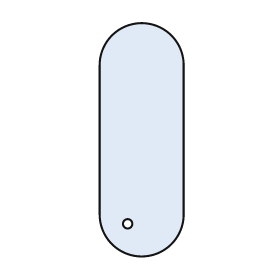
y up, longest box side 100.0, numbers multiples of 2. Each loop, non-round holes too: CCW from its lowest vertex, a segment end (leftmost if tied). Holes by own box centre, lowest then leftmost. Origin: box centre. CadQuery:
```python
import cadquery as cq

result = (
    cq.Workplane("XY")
    .moveTo(-18.0, -32.0)
    .threePointArc((0.0, -50.0), (18.0, -32.0))
    .lineTo(18.0, 32.0)
    .threePointArc((0.0, 50.0), (-18.0, 32.0))
    .close()
    .moveTo(-6.0, -36.0)
    .circle(2.0)
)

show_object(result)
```